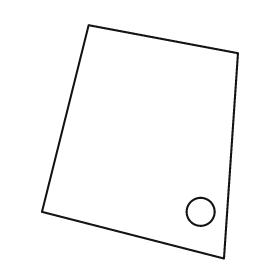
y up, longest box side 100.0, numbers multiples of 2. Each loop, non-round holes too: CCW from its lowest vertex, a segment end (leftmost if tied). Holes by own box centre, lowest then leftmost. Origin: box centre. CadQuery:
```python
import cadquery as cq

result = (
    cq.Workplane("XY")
    .moveTo(36.0, -50.0)
    .lineTo(42.0, 38.0)
    .lineTo(-22.0, 50.0)
    .lineTo(-42.0, -30.0)
    .close()
    .moveTo(26.0, -30.0)
    .circle(6.0)
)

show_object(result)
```